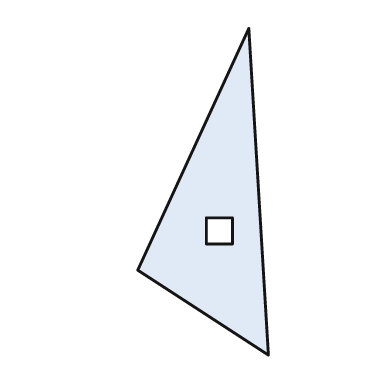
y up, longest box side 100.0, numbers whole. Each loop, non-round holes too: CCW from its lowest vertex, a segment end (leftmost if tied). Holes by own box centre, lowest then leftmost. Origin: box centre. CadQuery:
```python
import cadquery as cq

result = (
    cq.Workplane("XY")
    .moveTo(20.0, -50.0)
    .lineTo(14.0, 50.0)
    .lineTo(-20.0, -24.0)
    .close()
    .moveTo(1.0, -16.0)
    .lineTo(9.0, -16.0)
    .lineTo(9.0, -8.0)
    .lineTo(1.0, -8.0)
    .close()
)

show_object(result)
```